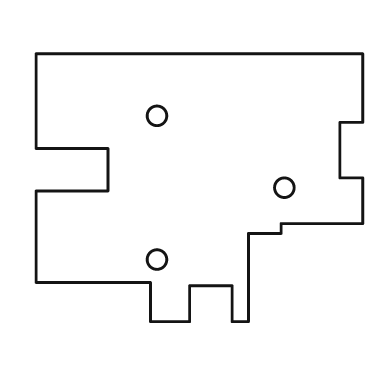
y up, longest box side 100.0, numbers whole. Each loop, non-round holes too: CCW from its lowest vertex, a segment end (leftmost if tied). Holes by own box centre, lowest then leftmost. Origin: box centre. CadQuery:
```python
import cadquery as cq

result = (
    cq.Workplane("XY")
    .moveTo(-15.0, -41.0)
    .lineTo(-3.0, -41.0)
    .lineTo(-3.0, -30.0)
    .lineTo(10.0, -30.0)
    .lineTo(10.0, -41.0)
    .lineTo(15.0, -41.0)
    .lineTo(15.0, -14.0)
    .lineTo(25.0, -14.0)
    .lineTo(25.0, -11.0)
    .lineTo(50.0, -11.0)
    .lineTo(50.0, 3.0)
    .lineTo(43.0, 3.0)
    .lineTo(43.0, 20.0)
    .lineTo(50.0, 20.0)
    .lineTo(50.0, 41.0)
    .lineTo(-50.0, 41.0)
    .lineTo(-50.0, 12.0)
    .lineTo(-28.0, 12.0)
    .lineTo(-28.0, -1.0)
    .lineTo(-50.0, -1.0)
    .lineTo(-50.0, -29.0)
    .lineTo(-15.0, -29.0)
    .close()
    .moveTo(-13.0, -22.0)
    .circle(3.0)
    .moveTo(26.0, 0.0)
    .circle(3.0)
    .moveTo(-13.0, 22.0)
    .circle(3.0)
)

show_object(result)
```